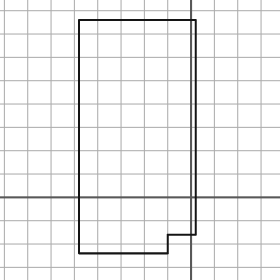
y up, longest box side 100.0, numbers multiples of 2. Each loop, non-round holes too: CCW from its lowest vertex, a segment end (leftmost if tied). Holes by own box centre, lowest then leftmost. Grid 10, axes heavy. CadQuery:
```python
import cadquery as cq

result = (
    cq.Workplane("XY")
    .moveTo(-48.0, -24.0)
    .lineTo(-10.0, -24.0)
    .lineTo(-10.0, -16.0)
    .lineTo(2.0, -16.0)
    .lineTo(2.0, 76.0)
    .lineTo(-48.0, 76.0)
    .close()
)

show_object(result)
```